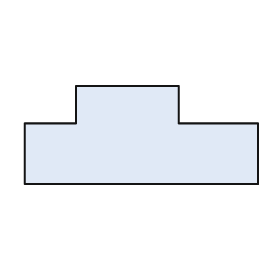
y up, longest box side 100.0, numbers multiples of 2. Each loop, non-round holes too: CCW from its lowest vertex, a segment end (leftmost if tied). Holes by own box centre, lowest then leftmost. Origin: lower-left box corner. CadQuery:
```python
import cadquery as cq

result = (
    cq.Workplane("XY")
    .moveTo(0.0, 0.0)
    .lineTo(100.0, 0.0)
    .lineTo(100.0, 26.0)
    .lineTo(66.0, 26.0)
    .lineTo(66.0, 42.0)
    .lineTo(22.0, 42.0)
    .lineTo(22.0, 26.0)
    .lineTo(0.0, 26.0)
    .close()
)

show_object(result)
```